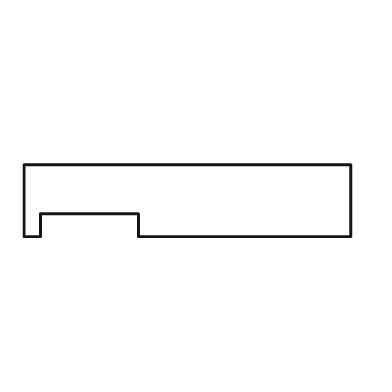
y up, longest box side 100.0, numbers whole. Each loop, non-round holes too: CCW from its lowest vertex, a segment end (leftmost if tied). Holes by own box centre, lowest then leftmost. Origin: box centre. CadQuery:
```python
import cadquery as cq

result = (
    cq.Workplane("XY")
    .moveTo(-50.0, -11.0)
    .lineTo(-45.0, -11.0)
    .lineTo(-45.0, -4.0)
    .lineTo(-15.0, -4.0)
    .lineTo(-15.0, -11.0)
    .lineTo(50.0, -11.0)
    .lineTo(50.0, 11.0)
    .lineTo(-50.0, 11.0)
    .close()
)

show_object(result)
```